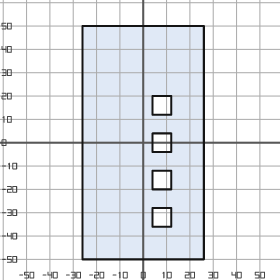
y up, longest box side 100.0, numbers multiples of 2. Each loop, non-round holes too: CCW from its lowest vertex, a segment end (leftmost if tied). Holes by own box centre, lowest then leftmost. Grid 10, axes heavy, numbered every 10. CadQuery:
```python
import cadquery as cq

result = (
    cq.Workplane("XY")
    .moveTo(-26.0, -50.0)
    .lineTo(26.0, -50.0)
    .lineTo(26.0, 50.0)
    .lineTo(-26.0, 50.0)
    .close()
    .moveTo(4.0, -36.0)
    .lineTo(12.0, -36.0)
    .lineTo(12.0, -28.0)
    .lineTo(4.0, -28.0)
    .close()
    .moveTo(4.0, -20.0)
    .lineTo(12.0, -20.0)
    .lineTo(12.0, -12.0)
    .lineTo(4.0, -12.0)
    .close()
    .moveTo(4.0, -4.0)
    .lineTo(12.0, -4.0)
    .lineTo(12.0, 4.0)
    .lineTo(4.0, 4.0)
    .close()
    .moveTo(4.0, 12.0)
    .lineTo(12.0, 12.0)
    .lineTo(12.0, 20.0)
    .lineTo(4.0, 20.0)
    .close()
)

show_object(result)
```